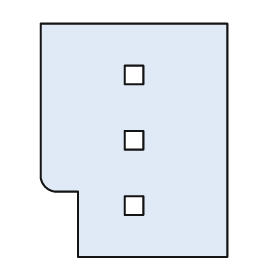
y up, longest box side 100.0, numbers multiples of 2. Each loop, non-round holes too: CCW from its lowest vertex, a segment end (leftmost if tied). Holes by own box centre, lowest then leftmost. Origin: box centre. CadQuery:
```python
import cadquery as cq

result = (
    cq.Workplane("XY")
    .moveTo(-24.0, -50.0)
    .lineTo(40.0, -50.0)
    .lineTo(40.0, 50.0)
    .lineTo(-40.0, 50.0)
    .lineTo(-40.0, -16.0)
    .threePointArc((-38.0, -20.0), (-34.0, -22.0))
    .lineTo(-24.0, -22.0)
    .close()
    .moveTo(-4.0, -32.0)
    .lineTo(4.0, -32.0)
    .lineTo(4.0, -24.0)
    .lineTo(-4.0, -24.0)
    .close()
    .moveTo(-4.0, -4.0)
    .lineTo(4.0, -4.0)
    .lineTo(4.0, 4.0)
    .lineTo(-4.0, 4.0)
    .close()
    .moveTo(-4.0, 24.0)
    .lineTo(4.0, 24.0)
    .lineTo(4.0, 32.0)
    .lineTo(-4.0, 32.0)
    .close()
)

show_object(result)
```